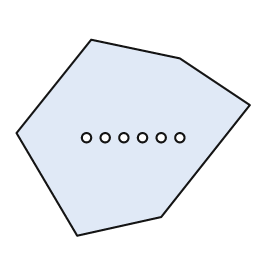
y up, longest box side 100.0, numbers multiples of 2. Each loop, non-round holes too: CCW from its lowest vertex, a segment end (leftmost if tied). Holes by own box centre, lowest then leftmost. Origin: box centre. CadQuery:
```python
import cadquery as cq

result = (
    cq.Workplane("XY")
    .moveTo(-24.0, -42.0)
    .lineTo(12.0, -34.0)
    .lineTo(50.0, 14.0)
    .lineTo(20.0, 34.0)
    .lineTo(-18.0, 42.0)
    .lineTo(-50.0, 2.0)
    .close()
    .moveTo(-20.0, 0.0)
    .circle(2.0)
    .moveTo(-12.0, 0.0)
    .circle(2.0)
    .moveTo(-4.0, 0.0)
    .circle(2.0)
    .moveTo(4.0, 0.0)
    .circle(2.0)
    .moveTo(12.0, 0.0)
    .circle(2.0)
    .moveTo(20.0, 0.0)
    .circle(2.0)
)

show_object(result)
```